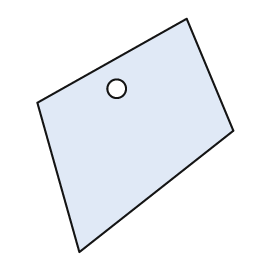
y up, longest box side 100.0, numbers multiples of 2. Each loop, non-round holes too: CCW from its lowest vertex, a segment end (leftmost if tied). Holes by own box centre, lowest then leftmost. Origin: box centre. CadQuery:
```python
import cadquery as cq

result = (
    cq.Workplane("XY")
    .moveTo(-24.0, -50.0)
    .lineTo(42.0, 2.0)
    .lineTo(22.0, 50.0)
    .lineTo(-42.0, 14.0)
    .close()
    .moveTo(-8.0, 20.0)
    .circle(4.0)
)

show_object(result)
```